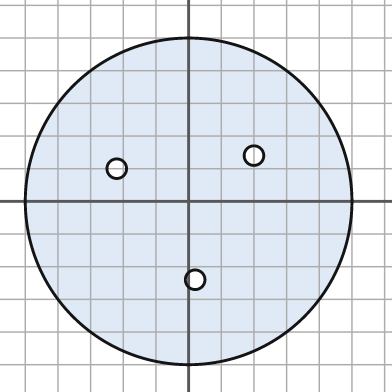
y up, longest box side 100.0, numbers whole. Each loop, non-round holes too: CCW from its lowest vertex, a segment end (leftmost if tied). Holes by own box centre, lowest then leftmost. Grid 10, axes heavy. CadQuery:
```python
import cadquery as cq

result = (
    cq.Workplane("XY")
    .moveTo(0.0, 0.0)
    .circle(50.0)
    .moveTo(2.0, -24.0)
    .circle(3.0)
    .moveTo(-22.0, 10.0)
    .circle(3.0)
    .moveTo(20.0, 14.0)
    .circle(3.0)
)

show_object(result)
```